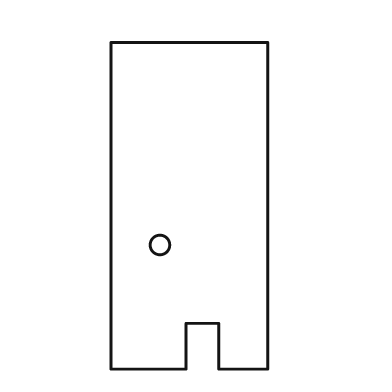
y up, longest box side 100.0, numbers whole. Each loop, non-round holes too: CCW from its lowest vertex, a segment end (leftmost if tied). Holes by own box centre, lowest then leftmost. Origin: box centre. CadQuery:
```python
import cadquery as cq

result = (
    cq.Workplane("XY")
    .moveTo(-24.0, -50.0)
    .lineTo(-1.0, -50.0)
    .lineTo(-1.0, -36.0)
    .lineTo(9.0, -36.0)
    .lineTo(9.0, -50.0)
    .lineTo(24.0, -50.0)
    .lineTo(24.0, 50.0)
    .lineTo(-24.0, 50.0)
    .close()
    .moveTo(-9.0, -12.0)
    .circle(3.0)
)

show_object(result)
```